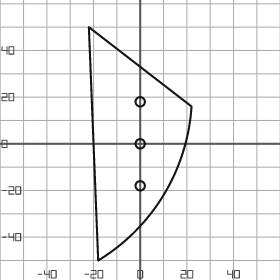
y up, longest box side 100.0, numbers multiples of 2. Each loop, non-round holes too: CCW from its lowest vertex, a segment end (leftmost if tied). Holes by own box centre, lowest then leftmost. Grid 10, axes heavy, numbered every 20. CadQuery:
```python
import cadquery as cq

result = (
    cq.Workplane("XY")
    .moveTo(-18.0, -50.0)
    .threePointArc((10.0, -22.0), (22.0, 16.0))
    .lineTo(-22.0, 50.0)
    .close()
    .moveTo(0.0, -18.0)
    .circle(2.0)
    .moveTo(0.0, 0.0)
    .circle(2.0)
    .moveTo(0.0, 18.0)
    .circle(2.0)
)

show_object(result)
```